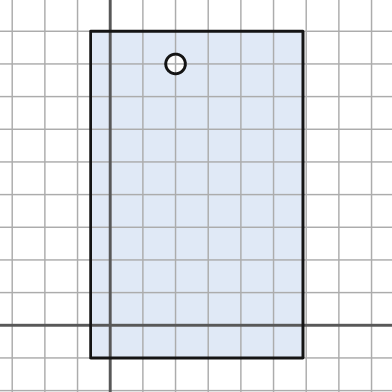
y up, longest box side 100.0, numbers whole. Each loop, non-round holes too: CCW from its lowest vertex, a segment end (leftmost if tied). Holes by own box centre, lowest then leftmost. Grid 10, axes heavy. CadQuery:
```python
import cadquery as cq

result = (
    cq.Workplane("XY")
    .moveTo(-6.0, -10.0)
    .lineTo(59.0, -10.0)
    .lineTo(59.0, 90.0)
    .lineTo(-6.0, 90.0)
    .close()
    .moveTo(20.0, 80.0)
    .circle(3.0)
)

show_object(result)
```